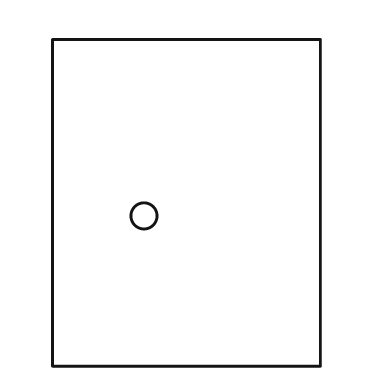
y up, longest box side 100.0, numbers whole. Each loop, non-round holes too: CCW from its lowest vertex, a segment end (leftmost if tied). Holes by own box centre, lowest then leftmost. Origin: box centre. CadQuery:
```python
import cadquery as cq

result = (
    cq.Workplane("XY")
    .moveTo(-41.0, -50.0)
    .lineTo(41.0, -50.0)
    .lineTo(41.0, 50.0)
    .lineTo(-41.0, 50.0)
    .close()
    .moveTo(-13.0, -4.0)
    .circle(4.0)
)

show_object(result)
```